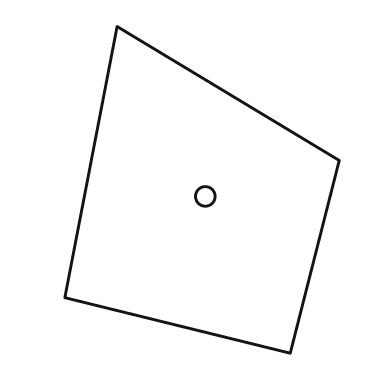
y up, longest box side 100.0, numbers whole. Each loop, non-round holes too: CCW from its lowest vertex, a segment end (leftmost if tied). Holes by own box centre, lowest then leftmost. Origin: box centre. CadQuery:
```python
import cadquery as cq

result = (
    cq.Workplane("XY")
    .moveTo(27.0, -50.0)
    .lineTo(42.0, 9.0)
    .lineTo(-26.0, 50.0)
    .lineTo(-42.0, -33.0)
    .close()
    .moveTo(1.0, -2.0)
    .circle(3.0)
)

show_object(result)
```